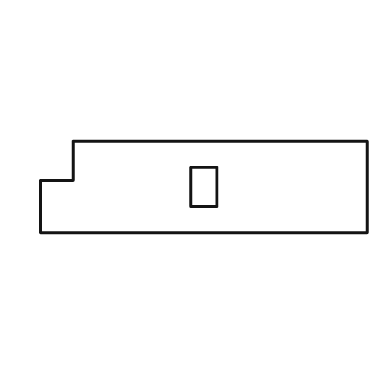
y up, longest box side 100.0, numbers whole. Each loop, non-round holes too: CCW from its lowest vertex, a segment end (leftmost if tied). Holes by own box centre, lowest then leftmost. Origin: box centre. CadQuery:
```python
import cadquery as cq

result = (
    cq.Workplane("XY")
    .moveTo(-50.0, -14.0)
    .lineTo(50.0, -14.0)
    .lineTo(50.0, 14.0)
    .lineTo(-40.0, 14.0)
    .lineTo(-40.0, 2.0)
    .lineTo(-50.0, 2.0)
    .close()
    .moveTo(-4.0, -6.0)
    .lineTo(4.0, -6.0)
    .lineTo(4.0, 6.0)
    .lineTo(-4.0, 6.0)
    .close()
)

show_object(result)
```